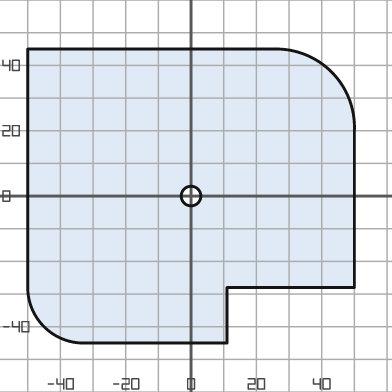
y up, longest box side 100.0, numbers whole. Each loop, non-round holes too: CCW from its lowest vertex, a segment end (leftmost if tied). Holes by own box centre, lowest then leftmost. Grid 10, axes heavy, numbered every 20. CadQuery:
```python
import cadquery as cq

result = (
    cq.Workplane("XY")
    .moveTo(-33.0, -45.0)
    .lineTo(11.0, -45.0)
    .lineTo(11.0, -28.0)
    .lineTo(50.0, -28.0)
    .lineTo(50.0, 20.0)
    .threePointArc((43.0, 38.0), (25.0, 45.0))
    .lineTo(-50.0, 45.0)
    .lineTo(-50.0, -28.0)
    .threePointArc((-45.0, -40.0), (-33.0, -45.0))
    .close()
    .moveTo(0.0, 0.0)
    .circle(3.0)
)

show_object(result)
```